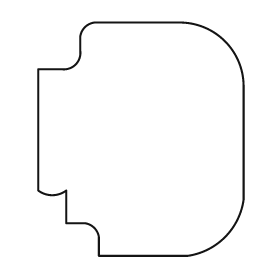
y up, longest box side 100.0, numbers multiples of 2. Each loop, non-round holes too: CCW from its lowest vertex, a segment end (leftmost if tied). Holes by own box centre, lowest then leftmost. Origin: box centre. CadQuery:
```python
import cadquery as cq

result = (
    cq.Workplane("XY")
    .moveTo(-18.0, -50.0)
    .lineTo(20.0, -50.0)
    .threePointArc((36.0, -42.0), (44.0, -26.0))
    .lineTo(44.0, 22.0)
    .threePointArc((36.0, 42.0), (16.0, 50.0))
    .lineTo(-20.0, 50.0)
    .threePointArc((-24.0, 48.0), (-26.0, 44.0))
    .lineTo(-26.0, 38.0)
    .threePointArc((-28.0, 32.0), (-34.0, 30.0))
    .lineTo(-44.0, 30.0)
    .lineTo(-44.0, -22.0)
    .threePointArc((-38.0, -24.0), (-32.0, -22.0))
    .lineTo(-32.0, -36.0)
    .lineTo(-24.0, -36.0)
    .threePointArc((-20.0, -38.0), (-18.0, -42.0))
    .close()
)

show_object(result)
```